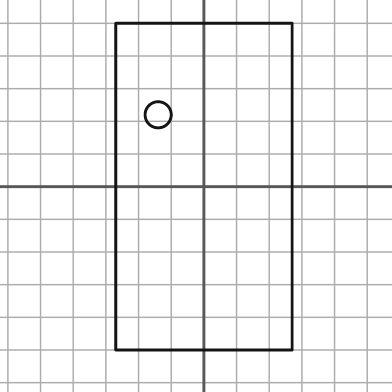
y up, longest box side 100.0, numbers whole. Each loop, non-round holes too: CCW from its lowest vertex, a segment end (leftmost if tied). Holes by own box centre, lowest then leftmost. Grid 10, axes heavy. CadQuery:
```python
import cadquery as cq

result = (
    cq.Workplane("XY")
    .moveTo(-27.0, -50.0)
    .lineTo(27.0, -50.0)
    .lineTo(27.0, 50.0)
    .lineTo(-27.0, 50.0)
    .close()
    .moveTo(-14.0, 22.0)
    .circle(4.0)
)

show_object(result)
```